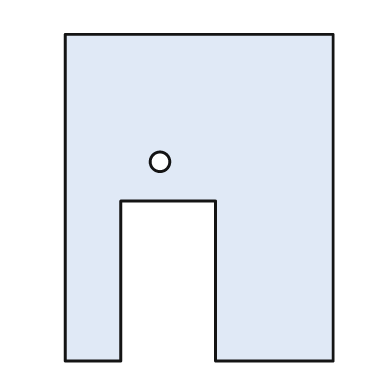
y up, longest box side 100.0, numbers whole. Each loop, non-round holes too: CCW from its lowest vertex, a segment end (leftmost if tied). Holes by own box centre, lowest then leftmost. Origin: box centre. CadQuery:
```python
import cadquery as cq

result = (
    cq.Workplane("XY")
    .moveTo(-41.0, -50.0)
    .lineTo(-24.0, -50.0)
    .lineTo(-24.0, -1.0)
    .lineTo(5.0, -1.0)
    .lineTo(5.0, -50.0)
    .lineTo(41.0, -50.0)
    .lineTo(41.0, 50.0)
    .lineTo(-41.0, 50.0)
    .close()
    .moveTo(-12.0, 11.0)
    .circle(3.0)
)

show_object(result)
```